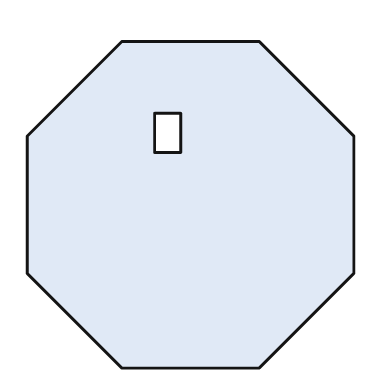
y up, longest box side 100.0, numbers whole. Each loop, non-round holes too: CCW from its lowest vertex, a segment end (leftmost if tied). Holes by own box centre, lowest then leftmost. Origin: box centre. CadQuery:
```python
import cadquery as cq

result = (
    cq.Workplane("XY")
    .moveTo(-21.0, -50.0)
    .lineTo(21.0, -50.0)
    .lineTo(50.0, -21.0)
    .lineTo(50.0, 21.0)
    .lineTo(21.0, 50.0)
    .lineTo(-21.0, 50.0)
    .lineTo(-50.0, 21.0)
    .lineTo(-50.0, -21.0)
    .close()
    .moveTo(-11.0, 16.0)
    .lineTo(-3.0, 16.0)
    .lineTo(-3.0, 28.0)
    .lineTo(-11.0, 28.0)
    .close()
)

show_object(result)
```